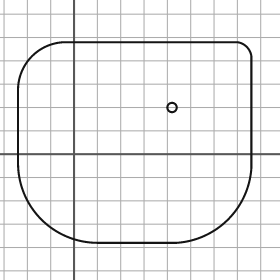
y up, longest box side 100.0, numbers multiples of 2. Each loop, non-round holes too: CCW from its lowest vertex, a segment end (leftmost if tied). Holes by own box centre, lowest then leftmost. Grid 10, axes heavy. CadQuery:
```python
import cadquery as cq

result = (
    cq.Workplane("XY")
    .moveTo(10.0, -38.0)
    .lineTo(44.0, -38.0)
    .threePointArc((66.0, -28.0), (76.0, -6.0))
    .lineTo(76.0, 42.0)
    .threePointArc((74.0, 46.0), (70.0, 48.0))
    .lineTo(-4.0, 48.0)
    .threePointArc((-18.0, 42.0), (-24.0, 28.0))
    .lineTo(-24.0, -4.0)
    .threePointArc((-14.0, -28.0), (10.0, -38.0))
    .close()
    .moveTo(42.0, 20.0)
    .circle(2.0)
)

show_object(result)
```